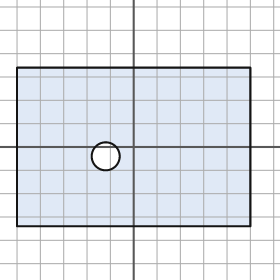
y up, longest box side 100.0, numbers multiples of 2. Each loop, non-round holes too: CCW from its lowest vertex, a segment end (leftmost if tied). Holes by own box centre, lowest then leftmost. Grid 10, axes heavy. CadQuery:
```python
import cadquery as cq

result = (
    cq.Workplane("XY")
    .moveTo(-50.0, -34.0)
    .lineTo(50.0, -34.0)
    .lineTo(50.0, 34.0)
    .lineTo(-50.0, 34.0)
    .close()
    .moveTo(-12.0, -4.0)
    .circle(6.0)
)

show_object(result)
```